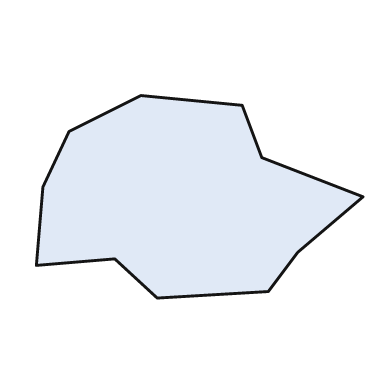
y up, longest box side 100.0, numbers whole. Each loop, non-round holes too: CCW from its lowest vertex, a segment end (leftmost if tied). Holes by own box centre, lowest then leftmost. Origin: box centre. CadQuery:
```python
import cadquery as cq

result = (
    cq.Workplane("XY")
    .moveTo(-13.0, -31.0)
    .lineTo(21.0, -29.0)
    .lineTo(30.0, -17.0)
    .lineTo(50.0, 0.0)
    .lineTo(19.0, 12.0)
    .lineTo(13.0, 28.0)
    .lineTo(-18.0, 31.0)
    .lineTo(-40.0, 20.0)
    .lineTo(-48.0, 3.0)
    .lineTo(-50.0, -21.0)
    .lineTo(-26.0, -19.0)
    .close()
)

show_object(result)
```